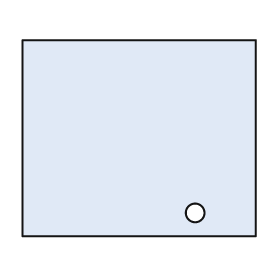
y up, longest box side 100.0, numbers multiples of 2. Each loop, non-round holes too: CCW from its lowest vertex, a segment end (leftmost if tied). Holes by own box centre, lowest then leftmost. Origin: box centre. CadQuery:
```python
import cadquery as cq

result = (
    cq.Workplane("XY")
    .moveTo(-50.0, -42.0)
    .lineTo(50.0, -42.0)
    .lineTo(50.0, 42.0)
    .lineTo(-50.0, 42.0)
    .close()
    .moveTo(24.0, -32.0)
    .circle(4.0)
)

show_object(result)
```